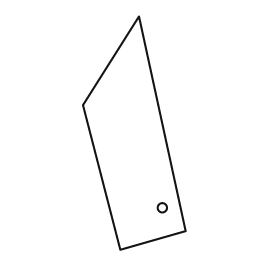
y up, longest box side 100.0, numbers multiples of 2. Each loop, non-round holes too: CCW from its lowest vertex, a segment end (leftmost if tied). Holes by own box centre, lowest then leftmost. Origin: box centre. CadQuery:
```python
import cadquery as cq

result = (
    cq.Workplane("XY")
    .moveTo(-6.0, -50.0)
    .lineTo(22.0, -42.0)
    .lineTo(2.0, 50.0)
    .lineTo(-22.0, 12.0)
    .close()
    .moveTo(12.0, -32.0)
    .circle(2.0)
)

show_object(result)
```